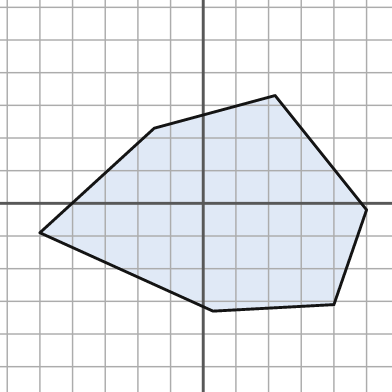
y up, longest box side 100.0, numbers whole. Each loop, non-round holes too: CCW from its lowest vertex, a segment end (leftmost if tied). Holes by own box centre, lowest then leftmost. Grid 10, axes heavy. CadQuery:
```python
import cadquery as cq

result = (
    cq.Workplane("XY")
    .moveTo(3.0, -33.0)
    .lineTo(40.0, -31.0)
    .lineTo(50.0, -2.0)
    .lineTo(22.0, 33.0)
    .lineTo(-15.0, 23.0)
    .lineTo(-50.0, -9.0)
    .close()
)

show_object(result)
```